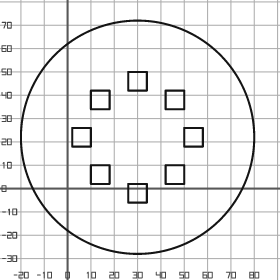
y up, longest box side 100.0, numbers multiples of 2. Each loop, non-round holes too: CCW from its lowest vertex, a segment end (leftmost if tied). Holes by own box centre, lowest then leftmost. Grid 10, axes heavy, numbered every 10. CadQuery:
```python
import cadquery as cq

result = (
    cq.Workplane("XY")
    .moveTo(30.0, 22.0)
    .circle(50.0)
    .moveTo(26.0, -6.0)
    .lineTo(34.0, -6.0)
    .lineTo(34.0, 2.0)
    .lineTo(26.0, 2.0)
    .close()
    .moveTo(10.0, 2.0)
    .lineTo(18.0, 2.0)
    .lineTo(18.0, 10.0)
    .lineTo(10.0, 10.0)
    .close()
    .moveTo(42.0, 2.0)
    .lineTo(50.0, 2.0)
    .lineTo(50.0, 10.0)
    .lineTo(42.0, 10.0)
    .close()
    .moveTo(2.0, 18.0)
    .lineTo(10.0, 18.0)
    .lineTo(10.0, 26.0)
    .lineTo(2.0, 26.0)
    .close()
    .moveTo(50.0, 18.0)
    .lineTo(58.0, 18.0)
    .lineTo(58.0, 26.0)
    .lineTo(50.0, 26.0)
    .close()
    .moveTo(10.0, 34.0)
    .lineTo(18.0, 34.0)
    .lineTo(18.0, 42.0)
    .lineTo(10.0, 42.0)
    .close()
    .moveTo(42.0, 34.0)
    .lineTo(50.0, 34.0)
    .lineTo(50.0, 42.0)
    .lineTo(42.0, 42.0)
    .close()
    .moveTo(26.0, 42.0)
    .lineTo(34.0, 42.0)
    .lineTo(34.0, 50.0)
    .lineTo(26.0, 50.0)
    .close()
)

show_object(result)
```